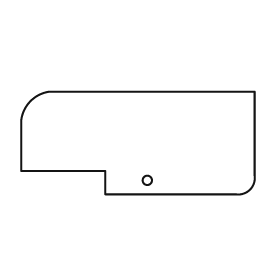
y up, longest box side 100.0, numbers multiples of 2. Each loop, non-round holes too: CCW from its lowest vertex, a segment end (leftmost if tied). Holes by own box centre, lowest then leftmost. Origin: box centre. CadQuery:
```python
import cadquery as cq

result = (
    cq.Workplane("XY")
    .moveTo(-14.0, -22.0)
    .lineTo(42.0, -22.0)
    .threePointArc((48.0, -20.0), (50.0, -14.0))
    .lineTo(50.0, 22.0)
    .lineTo(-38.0, 22.0)
    .threePointArc((-46.0, 18.0), (-50.0, 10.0))
    .lineTo(-50.0, -12.0)
    .lineTo(-14.0, -12.0)
    .close()
    .moveTo(4.0, -16.0)
    .circle(2.0)
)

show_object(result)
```